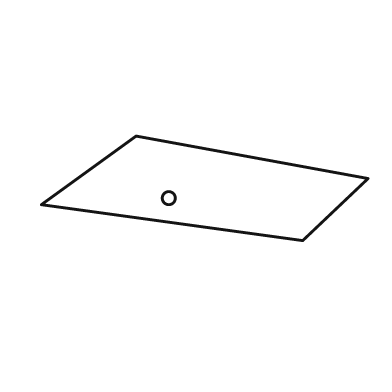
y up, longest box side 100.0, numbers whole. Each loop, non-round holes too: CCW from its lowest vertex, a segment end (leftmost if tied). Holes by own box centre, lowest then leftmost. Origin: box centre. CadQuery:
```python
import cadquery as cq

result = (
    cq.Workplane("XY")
    .moveTo(30.0, -16.0)
    .lineTo(50.0, 3.0)
    .lineTo(-21.0, 16.0)
    .lineTo(-50.0, -5.0)
    .close()
    .moveTo(-11.0, -3.0)
    .circle(2.0)
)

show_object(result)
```